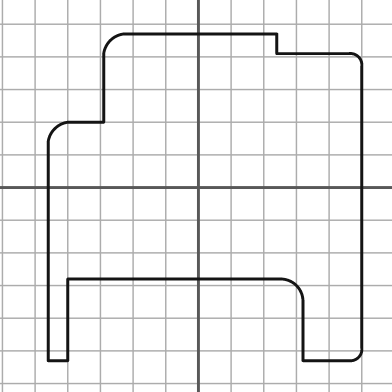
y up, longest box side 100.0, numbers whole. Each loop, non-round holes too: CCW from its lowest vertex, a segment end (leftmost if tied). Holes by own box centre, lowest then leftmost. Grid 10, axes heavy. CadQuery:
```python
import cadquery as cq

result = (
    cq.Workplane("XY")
    .moveTo(-46.0, -53.0)
    .lineTo(-40.0, -53.0)
    .lineTo(-40.0, -28.0)
    .lineTo(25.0, -28.0)
    .threePointArc((30.0, -30.0), (32.0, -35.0))
    .lineTo(32.0, -53.0)
    .lineTo(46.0, -53.0)
    .threePointArc((49.0, -52.0), (50.0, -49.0))
    .lineTo(50.0, 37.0)
    .threePointArc((49.0, 40.0), (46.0, 41.0))
    .lineTo(24.0, 41.0)
    .lineTo(24.0, 47.0)
    .lineTo(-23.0, 47.0)
    .threePointArc((-27.0, 45.0), (-29.0, 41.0))
    .lineTo(-29.0, 20.0)
    .lineTo(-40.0, 20.0)
    .threePointArc((-44.0, 18.0), (-46.0, 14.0))
    .close()
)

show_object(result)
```